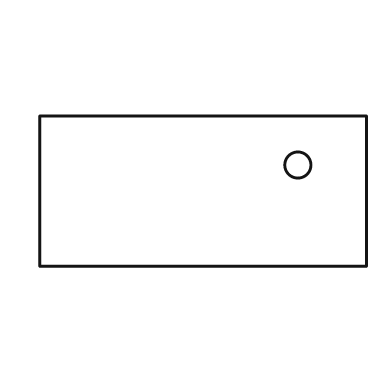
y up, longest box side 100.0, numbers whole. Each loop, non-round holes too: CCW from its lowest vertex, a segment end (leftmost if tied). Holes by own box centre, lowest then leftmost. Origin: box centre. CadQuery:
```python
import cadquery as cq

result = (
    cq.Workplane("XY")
    .moveTo(-50.0, -23.0)
    .lineTo(50.0, -23.0)
    .lineTo(50.0, 23.0)
    .lineTo(-50.0, 23.0)
    .close()
    .moveTo(29.0, 8.0)
    .circle(4.0)
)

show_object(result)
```